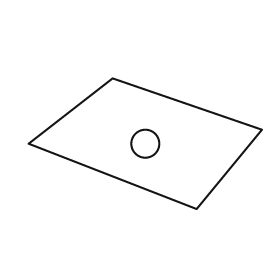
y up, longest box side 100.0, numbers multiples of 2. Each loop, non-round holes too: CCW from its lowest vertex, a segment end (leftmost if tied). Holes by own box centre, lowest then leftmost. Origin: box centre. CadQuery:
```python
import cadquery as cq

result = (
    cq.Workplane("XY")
    .moveTo(22.0, -28.0)
    .lineTo(50.0, 6.0)
    .lineTo(-14.0, 28.0)
    .lineTo(-50.0, 0.0)
    .close()
    .moveTo(0.0, 0.0)
    .circle(6.0)
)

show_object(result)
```